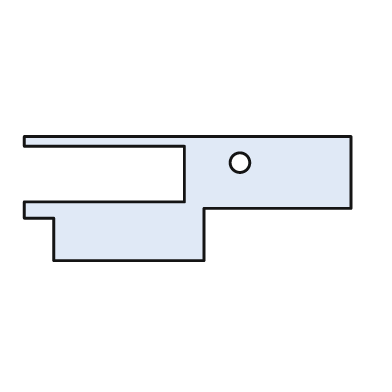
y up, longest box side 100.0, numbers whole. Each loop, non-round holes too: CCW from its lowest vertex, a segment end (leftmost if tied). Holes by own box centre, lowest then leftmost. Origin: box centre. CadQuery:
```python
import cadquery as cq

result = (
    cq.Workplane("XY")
    .moveTo(-41.0, -19.0)
    .lineTo(5.0, -19.0)
    .lineTo(5.0, -3.0)
    .lineTo(50.0, -3.0)
    .lineTo(50.0, 19.0)
    .lineTo(-50.0, 19.0)
    .lineTo(-50.0, 16.0)
    .lineTo(-1.0, 16.0)
    .lineTo(-1.0, -1.0)
    .lineTo(-50.0, -1.0)
    .lineTo(-50.0, -6.0)
    .lineTo(-41.0, -6.0)
    .close()
    .moveTo(16.0, 11.0)
    .circle(3.0)
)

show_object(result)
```